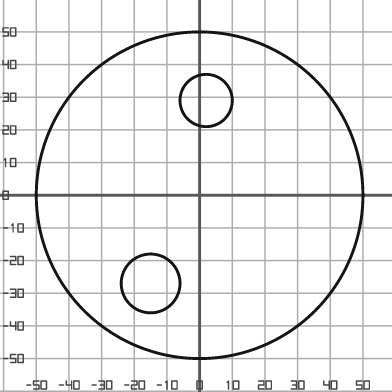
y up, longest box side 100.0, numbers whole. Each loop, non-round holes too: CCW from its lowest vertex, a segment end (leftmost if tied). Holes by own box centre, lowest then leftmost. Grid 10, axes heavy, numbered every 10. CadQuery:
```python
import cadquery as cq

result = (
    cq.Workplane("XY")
    .moveTo(0.0, 0.0)
    .circle(50.0)
    .moveTo(-15.0, -27.0)
    .circle(9.0)
    .moveTo(2.0, 29.0)
    .circle(8.0)
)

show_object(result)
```